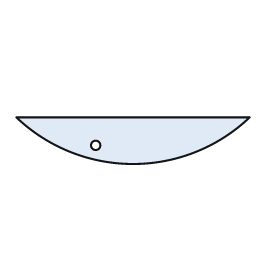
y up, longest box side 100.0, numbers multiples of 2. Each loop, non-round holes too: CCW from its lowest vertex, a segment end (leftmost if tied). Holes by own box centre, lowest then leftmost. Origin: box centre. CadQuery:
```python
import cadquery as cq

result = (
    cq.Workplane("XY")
    .moveTo(-50.0, 10.0)
    .threePointArc((0.0, -10.0), (50.0, 10.0))
    .close()
    .moveTo(-16.0, -2.0)
    .circle(2.0)
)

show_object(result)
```